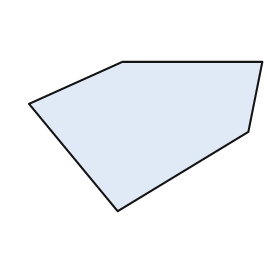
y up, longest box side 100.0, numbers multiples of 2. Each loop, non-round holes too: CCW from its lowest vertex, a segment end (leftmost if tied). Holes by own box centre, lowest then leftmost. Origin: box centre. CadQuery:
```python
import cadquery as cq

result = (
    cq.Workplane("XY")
    .moveTo(-12.0, -32.0)
    .lineTo(44.0, 2.0)
    .lineTo(50.0, 32.0)
    .lineTo(-10.0, 32.0)
    .lineTo(-50.0, 14.0)
    .close()
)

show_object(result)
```